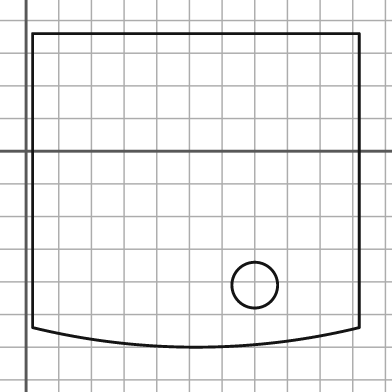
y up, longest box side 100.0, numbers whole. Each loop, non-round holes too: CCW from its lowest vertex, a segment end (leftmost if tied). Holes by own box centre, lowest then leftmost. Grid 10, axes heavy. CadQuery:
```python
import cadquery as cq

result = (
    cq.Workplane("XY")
    .moveTo(2.0, -54.0)
    .threePointArc((52.0, -60.0), (102.0, -54.0))
    .lineTo(102.0, 36.0)
    .lineTo(2.0, 36.0)
    .close()
    .moveTo(70.0, -41.0)
    .circle(7.0)
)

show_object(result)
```